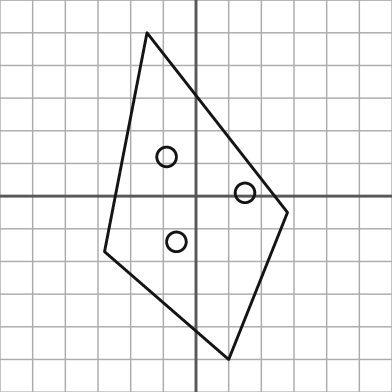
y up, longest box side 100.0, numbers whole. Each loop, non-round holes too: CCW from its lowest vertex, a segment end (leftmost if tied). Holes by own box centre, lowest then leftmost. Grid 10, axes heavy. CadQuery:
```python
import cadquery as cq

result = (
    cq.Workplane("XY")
    .moveTo(10.0, -50.0)
    .lineTo(28.0, -5.0)
    .lineTo(-15.0, 50.0)
    .lineTo(-28.0, -17.0)
    .close()
    .moveTo(-6.0, -14.0)
    .circle(3.0)
    .moveTo(15.0, 1.0)
    .circle(3.0)
    .moveTo(-9.0, 12.0)
    .circle(3.0)
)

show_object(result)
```